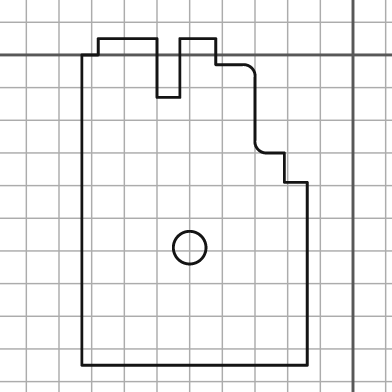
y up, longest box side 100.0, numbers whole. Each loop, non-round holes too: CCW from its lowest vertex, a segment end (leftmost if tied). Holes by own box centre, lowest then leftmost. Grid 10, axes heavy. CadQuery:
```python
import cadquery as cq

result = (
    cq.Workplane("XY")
    .moveTo(-83.0, -95.0)
    .lineTo(-14.0, -95.0)
    .lineTo(-14.0, -39.0)
    .lineTo(-21.0, -39.0)
    .lineTo(-21.0, -30.0)
    .lineTo(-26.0, -30.0)
    .threePointArc((-29.0, -29.0), (-30.0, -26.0))
    .lineTo(-30.0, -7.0)
    .threePointArc((-31.0, -4.0), (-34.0, -3.0))
    .lineTo(-42.0, -3.0)
    .lineTo(-42.0, 5.0)
    .lineTo(-53.0, 5.0)
    .lineTo(-53.0, -13.0)
    .lineTo(-60.0, -13.0)
    .lineTo(-60.0, 5.0)
    .lineTo(-78.0, 5.0)
    .lineTo(-78.0, 0.0)
    .lineTo(-83.0, 0.0)
    .close()
    .moveTo(-50.0, -59.0)
    .circle(5.0)
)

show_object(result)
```